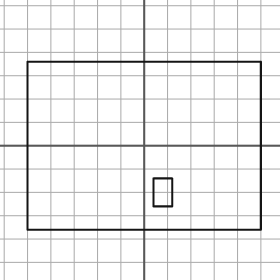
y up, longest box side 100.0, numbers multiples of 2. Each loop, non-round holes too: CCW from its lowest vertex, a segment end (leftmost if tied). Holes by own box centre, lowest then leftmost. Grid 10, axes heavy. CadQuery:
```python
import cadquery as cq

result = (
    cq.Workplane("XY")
    .moveTo(-50.0, -36.0)
    .lineTo(50.0, -36.0)
    .lineTo(50.0, 36.0)
    .lineTo(-50.0, 36.0)
    .close()
    .moveTo(4.0, -26.0)
    .lineTo(12.0, -26.0)
    .lineTo(12.0, -14.0)
    .lineTo(4.0, -14.0)
    .close()
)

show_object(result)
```